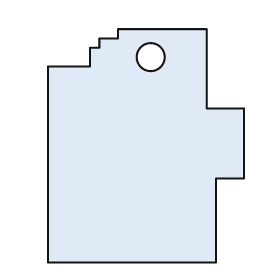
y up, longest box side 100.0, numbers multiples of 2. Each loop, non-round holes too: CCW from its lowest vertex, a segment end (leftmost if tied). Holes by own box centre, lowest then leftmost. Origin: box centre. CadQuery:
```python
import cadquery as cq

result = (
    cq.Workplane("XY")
    .moveTo(-42.0, -50.0)
    .lineTo(30.0, -50.0)
    .lineTo(30.0, -14.0)
    .lineTo(42.0, -14.0)
    .lineTo(42.0, 16.0)
    .lineTo(26.0, 16.0)
    .lineTo(26.0, 50.0)
    .lineTo(-12.0, 50.0)
    .lineTo(-12.0, 46.0)
    .lineTo(-20.0, 46.0)
    .lineTo(-20.0, 42.0)
    .lineTo(-24.0, 42.0)
    .lineTo(-24.0, 34.0)
    .lineTo(-42.0, 34.0)
    .close()
    .moveTo(2.0, 38.0)
    .circle(6.0)
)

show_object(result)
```